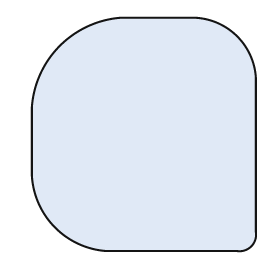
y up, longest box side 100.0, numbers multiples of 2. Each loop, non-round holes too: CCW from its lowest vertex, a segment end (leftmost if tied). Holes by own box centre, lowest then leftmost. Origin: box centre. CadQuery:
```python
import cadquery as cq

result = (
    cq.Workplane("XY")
    .moveTo(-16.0, -50.0)
    .lineTo(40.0, -50.0)
    .threePointArc((46.0, -48.0), (48.0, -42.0))
    .lineTo(48.0, 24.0)
    .threePointArc((40.0, 42.0), (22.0, 50.0))
    .lineTo(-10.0, 50.0)
    .threePointArc((-36.0, 38.0), (-48.0, 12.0))
    .lineTo(-48.0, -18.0)
    .threePointArc((-38.0, -40.0), (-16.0, -50.0))
    .close()
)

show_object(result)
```